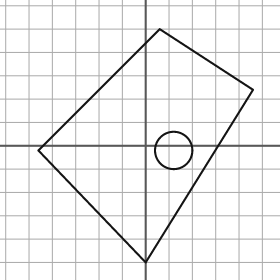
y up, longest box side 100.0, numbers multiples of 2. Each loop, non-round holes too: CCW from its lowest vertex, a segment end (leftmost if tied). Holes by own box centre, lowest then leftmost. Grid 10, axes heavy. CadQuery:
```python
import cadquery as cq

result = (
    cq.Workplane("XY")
    .moveTo(0.0, -50.0)
    .lineTo(46.0, 24.0)
    .lineTo(6.0, 50.0)
    .lineTo(-46.0, -2.0)
    .close()
    .moveTo(12.0, -2.0)
    .circle(8.0)
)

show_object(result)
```